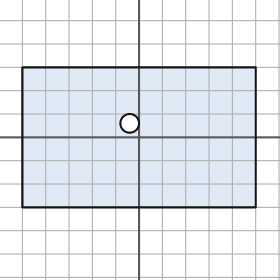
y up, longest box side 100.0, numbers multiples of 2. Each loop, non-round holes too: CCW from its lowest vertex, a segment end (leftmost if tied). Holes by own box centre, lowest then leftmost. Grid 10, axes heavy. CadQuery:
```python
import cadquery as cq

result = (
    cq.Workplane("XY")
    .moveTo(-50.0, -30.0)
    .lineTo(50.0, -30.0)
    .lineTo(50.0, 30.0)
    .lineTo(-50.0, 30.0)
    .close()
    .moveTo(-4.0, 6.0)
    .circle(4.0)
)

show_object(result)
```